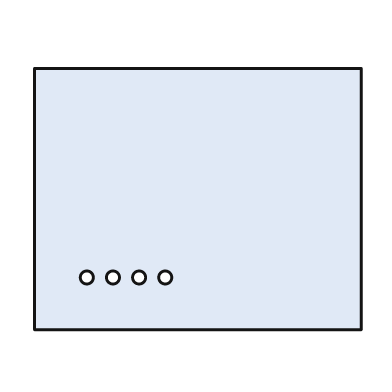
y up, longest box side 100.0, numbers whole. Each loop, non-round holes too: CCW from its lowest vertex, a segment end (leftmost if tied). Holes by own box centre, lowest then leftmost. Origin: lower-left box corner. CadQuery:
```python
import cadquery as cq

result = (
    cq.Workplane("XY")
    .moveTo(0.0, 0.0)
    .lineTo(100.0, 0.0)
    .lineTo(100.0, 80.0)
    .lineTo(0.0, 80.0)
    .close()
    .moveTo(16.0, 16.0)
    .circle(2.0)
    .moveTo(24.0, 16.0)
    .circle(2.0)
    .moveTo(32.0, 16.0)
    .circle(2.0)
    .moveTo(40.0, 16.0)
    .circle(2.0)
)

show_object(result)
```